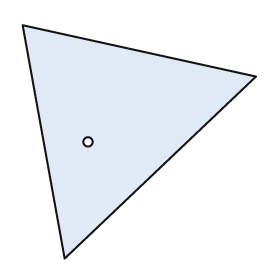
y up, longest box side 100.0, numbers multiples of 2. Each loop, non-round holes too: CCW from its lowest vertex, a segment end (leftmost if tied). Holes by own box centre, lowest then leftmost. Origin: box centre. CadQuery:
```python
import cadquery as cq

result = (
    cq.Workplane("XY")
    .moveTo(-32.0, -50.0)
    .lineTo(50.0, 28.0)
    .lineTo(-50.0, 50.0)
    .close()
    .moveTo(-22.0, 0.0)
    .circle(2.0)
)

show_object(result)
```